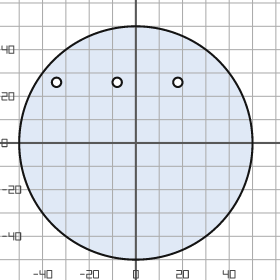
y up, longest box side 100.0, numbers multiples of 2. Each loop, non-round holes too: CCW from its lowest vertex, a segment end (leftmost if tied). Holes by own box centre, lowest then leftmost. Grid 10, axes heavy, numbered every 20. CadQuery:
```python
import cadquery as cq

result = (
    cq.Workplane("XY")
    .moveTo(0.0, 0.0)
    .circle(50.0)
    .moveTo(-34.0, 26.0)
    .circle(2.0)
    .moveTo(-8.0, 26.0)
    .circle(2.0)
    .moveTo(18.0, 26.0)
    .circle(2.0)
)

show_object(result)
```